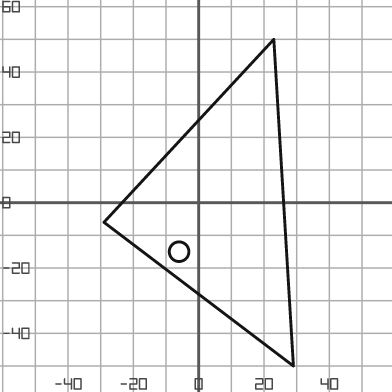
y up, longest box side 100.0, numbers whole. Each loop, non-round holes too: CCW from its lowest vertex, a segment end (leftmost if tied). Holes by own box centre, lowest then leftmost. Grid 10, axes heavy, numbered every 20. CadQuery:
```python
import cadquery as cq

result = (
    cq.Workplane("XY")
    .moveTo(29.0, -50.0)
    .lineTo(23.0, 50.0)
    .lineTo(-29.0, -6.0)
    .close()
    .moveTo(-6.0, -15.0)
    .circle(3.0)
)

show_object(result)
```